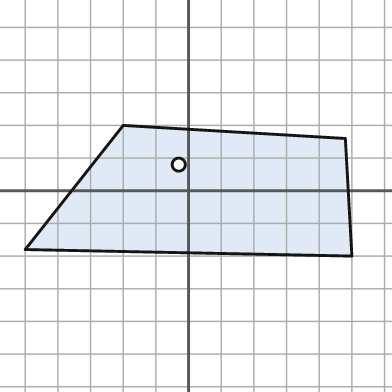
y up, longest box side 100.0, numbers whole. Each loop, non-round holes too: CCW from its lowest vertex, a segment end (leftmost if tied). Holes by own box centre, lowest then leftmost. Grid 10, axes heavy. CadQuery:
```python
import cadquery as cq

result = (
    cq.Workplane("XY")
    .moveTo(50.0, -20.0)
    .lineTo(48.0, 16.0)
    .lineTo(-20.0, 20.0)
    .lineTo(-50.0, -18.0)
    .close()
    .moveTo(-3.0, 8.0)
    .circle(2.0)
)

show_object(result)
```